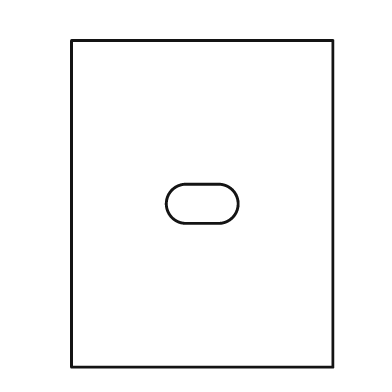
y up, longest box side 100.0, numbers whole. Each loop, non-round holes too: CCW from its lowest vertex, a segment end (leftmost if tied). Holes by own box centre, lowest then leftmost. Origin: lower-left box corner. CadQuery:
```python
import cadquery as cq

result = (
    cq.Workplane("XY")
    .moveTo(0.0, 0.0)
    .lineTo(80.0, 0.0)
    .lineTo(80.0, 100.0)
    .lineTo(0.0, 100.0)
    .close()
    .moveTo(35.0, 44.0)
    .lineTo(45.0, 44.0)
    .threePointArc((51.0, 50.0), (45.0, 56.0))
    .lineTo(35.0, 56.0)
    .threePointArc((29.0, 50.0), (35.0, 44.0))
    .close()
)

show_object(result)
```